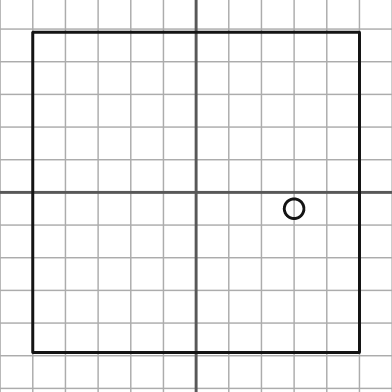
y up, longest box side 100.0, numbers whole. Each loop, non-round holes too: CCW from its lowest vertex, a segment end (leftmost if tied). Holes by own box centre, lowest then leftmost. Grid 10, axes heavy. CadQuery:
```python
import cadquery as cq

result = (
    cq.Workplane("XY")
    .moveTo(-50.0, -49.0)
    .lineTo(50.0, -49.0)
    .lineTo(50.0, 49.0)
    .lineTo(-50.0, 49.0)
    .close()
    .moveTo(30.0, -5.0)
    .circle(3.0)
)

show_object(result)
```